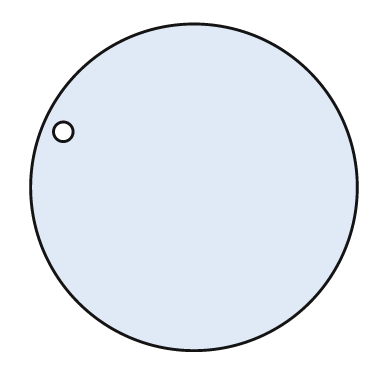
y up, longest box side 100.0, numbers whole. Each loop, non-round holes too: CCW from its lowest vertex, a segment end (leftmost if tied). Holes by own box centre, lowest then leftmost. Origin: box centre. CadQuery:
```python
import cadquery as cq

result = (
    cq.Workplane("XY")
    .moveTo(0.0, 0.0)
    .circle(50.0)
    .moveTo(-40.0, 17.0)
    .circle(3.0)
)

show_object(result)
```